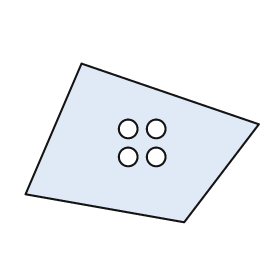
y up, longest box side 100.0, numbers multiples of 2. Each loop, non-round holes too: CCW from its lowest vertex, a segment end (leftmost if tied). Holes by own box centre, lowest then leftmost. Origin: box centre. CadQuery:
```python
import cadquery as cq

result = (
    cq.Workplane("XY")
    .moveTo(18.0, -34.0)
    .lineTo(50.0, 8.0)
    .lineTo(-26.0, 34.0)
    .lineTo(-50.0, -22.0)
    .close()
    .moveTo(-6.0, -6.0)
    .circle(4.0)
    .moveTo(6.0, -6.0)
    .circle(4.0)
    .moveTo(-6.0, 6.0)
    .circle(4.0)
    .moveTo(6.0, 6.0)
    .circle(4.0)
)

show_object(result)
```